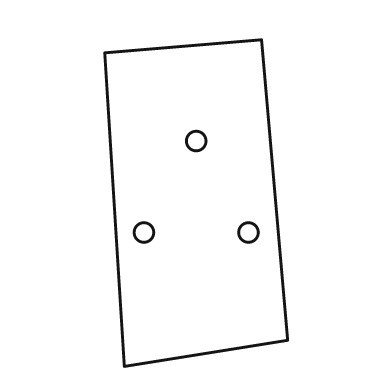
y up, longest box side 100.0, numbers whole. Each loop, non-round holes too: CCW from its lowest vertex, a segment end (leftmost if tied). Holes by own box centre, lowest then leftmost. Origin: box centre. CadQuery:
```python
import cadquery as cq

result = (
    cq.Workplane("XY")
    .moveTo(-22.0, -50.0)
    .lineTo(28.0, -42.0)
    .lineTo(20.0, 50.0)
    .lineTo(-28.0, 46.0)
    .close()
    .moveTo(-16.0, -9.0)
    .circle(3.0)
    .moveTo(16.0, -9.0)
    .circle(3.0)
    .moveTo(0.0, 19.0)
    .circle(3.0)
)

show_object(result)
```